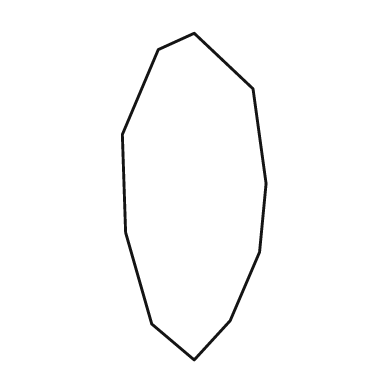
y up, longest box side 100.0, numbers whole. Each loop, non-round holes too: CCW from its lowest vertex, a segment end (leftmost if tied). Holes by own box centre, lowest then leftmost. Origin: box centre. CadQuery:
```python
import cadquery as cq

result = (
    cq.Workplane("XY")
    .moveTo(0.0, -50.0)
    .lineTo(11.0, -38.0)
    .lineTo(20.0, -17.0)
    .lineTo(22.0, 4.0)
    .lineTo(18.0, 33.0)
    .lineTo(0.0, 50.0)
    .lineTo(-11.0, 45.0)
    .lineTo(-22.0, 19.0)
    .lineTo(-21.0, -11.0)
    .lineTo(-13.0, -39.0)
    .close()
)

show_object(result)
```